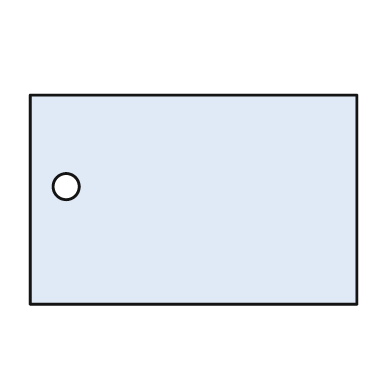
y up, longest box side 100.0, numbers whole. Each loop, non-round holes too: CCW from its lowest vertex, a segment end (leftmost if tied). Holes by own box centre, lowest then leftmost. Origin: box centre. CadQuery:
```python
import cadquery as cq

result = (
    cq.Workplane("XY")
    .moveTo(-50.0, -32.0)
    .lineTo(50.0, -32.0)
    .lineTo(50.0, 32.0)
    .lineTo(-50.0, 32.0)
    .close()
    .moveTo(-39.0, 4.0)
    .circle(4.0)
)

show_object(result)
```